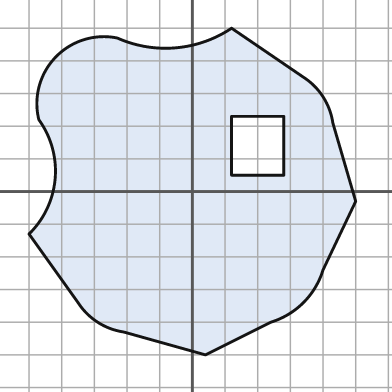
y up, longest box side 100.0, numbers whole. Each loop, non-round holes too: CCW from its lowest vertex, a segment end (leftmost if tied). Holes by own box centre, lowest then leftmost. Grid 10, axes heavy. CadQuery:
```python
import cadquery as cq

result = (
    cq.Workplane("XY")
    .moveTo(4.0, -50.0)
    .lineTo(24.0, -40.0)
    .threePointArc((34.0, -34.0), (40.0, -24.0))
    .lineTo(50.0, -3.0)
    .lineTo(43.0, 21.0)
    .threePointArc((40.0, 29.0), (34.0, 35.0))
    .lineTo(12.0, 50.0)
    .threePointArc((-5.0, 44.0), (-23.0, 47.0))
    .threePointArc((-42.0, 41.0), (-47.0, 22.0))
    .threePointArc((-42.0, 4.0), (-50.0, -13.0))
    .lineTo(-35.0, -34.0)
    .threePointArc((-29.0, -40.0), (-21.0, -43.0))
    .close()
    .moveTo(12.0, 5.0)
    .lineTo(28.0, 5.0)
    .lineTo(28.0, 23.0)
    .lineTo(12.0, 23.0)
    .close()
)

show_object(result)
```